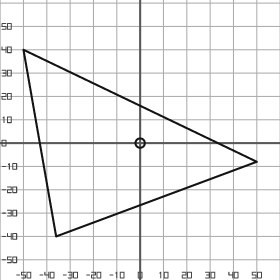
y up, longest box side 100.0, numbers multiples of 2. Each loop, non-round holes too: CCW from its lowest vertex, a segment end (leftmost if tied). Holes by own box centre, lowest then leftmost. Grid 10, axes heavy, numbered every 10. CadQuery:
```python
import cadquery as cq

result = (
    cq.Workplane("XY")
    .moveTo(-36.0, -40.0)
    .lineTo(50.0, -8.0)
    .lineTo(-50.0, 40.0)
    .close()
    .moveTo(0.0, 0.0)
    .circle(2.0)
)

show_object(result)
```